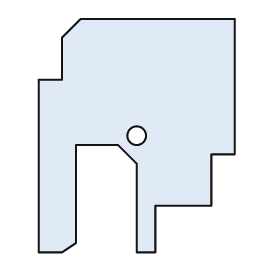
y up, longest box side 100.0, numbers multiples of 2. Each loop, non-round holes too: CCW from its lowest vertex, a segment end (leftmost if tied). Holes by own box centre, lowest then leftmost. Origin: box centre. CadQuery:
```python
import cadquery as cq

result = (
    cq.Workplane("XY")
    .moveTo(-42.0, -50.0)
    .lineTo(-32.0, -50.0)
    .lineTo(-26.0, -46.0)
    .lineTo(-26.0, -4.0)
    .lineTo(-8.0, -4.0)
    .lineTo(0.0, -12.0)
    .lineTo(0.0, -50.0)
    .lineTo(8.0, -50.0)
    .lineTo(8.0, -30.0)
    .lineTo(32.0, -30.0)
    .lineTo(32.0, -8.0)
    .lineTo(42.0, -8.0)
    .lineTo(42.0, 50.0)
    .lineTo(-24.0, 50.0)
    .lineTo(-32.0, 42.0)
    .lineTo(-32.0, 24.0)
    .lineTo(-42.0, 24.0)
    .close()
    .moveTo(0.0, 0.0)
    .circle(4.0)
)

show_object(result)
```